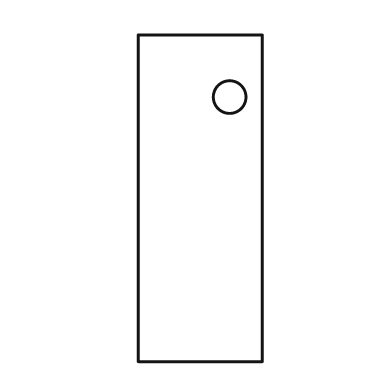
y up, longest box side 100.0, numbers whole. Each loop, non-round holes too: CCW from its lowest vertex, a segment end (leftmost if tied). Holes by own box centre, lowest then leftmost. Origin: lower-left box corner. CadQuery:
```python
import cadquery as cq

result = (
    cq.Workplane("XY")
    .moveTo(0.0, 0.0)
    .lineTo(38.0, 0.0)
    .lineTo(38.0, 100.0)
    .lineTo(0.0, 100.0)
    .close()
    .moveTo(28.0, 81.0)
    .circle(5.0)
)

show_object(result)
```